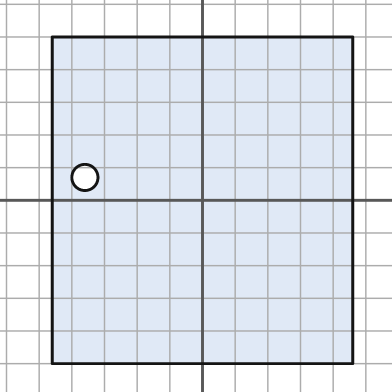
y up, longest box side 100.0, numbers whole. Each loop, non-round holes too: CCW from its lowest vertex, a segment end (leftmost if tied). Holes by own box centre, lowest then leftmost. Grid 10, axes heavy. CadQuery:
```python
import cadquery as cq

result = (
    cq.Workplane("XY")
    .moveTo(-46.0, -50.0)
    .lineTo(46.0, -50.0)
    .lineTo(46.0, 50.0)
    .lineTo(-46.0, 50.0)
    .close()
    .moveTo(-36.0, 7.0)
    .circle(4.0)
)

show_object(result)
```